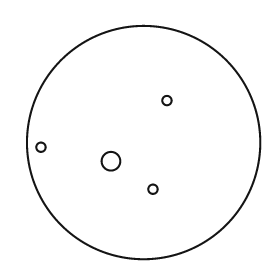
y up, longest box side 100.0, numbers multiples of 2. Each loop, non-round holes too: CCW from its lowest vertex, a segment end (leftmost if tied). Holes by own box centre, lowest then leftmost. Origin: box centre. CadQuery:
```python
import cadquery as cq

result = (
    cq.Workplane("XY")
    .moveTo(0.0, 0.0)
    .circle(50.0)
    .moveTo(4.0, -20.0)
    .circle(2.0)
    .moveTo(-14.0, -8.0)
    .circle(4.0)
    .moveTo(-44.0, -2.0)
    .circle(2.0)
    .moveTo(10.0, 18.0)
    .circle(2.0)
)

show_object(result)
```